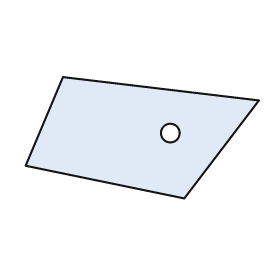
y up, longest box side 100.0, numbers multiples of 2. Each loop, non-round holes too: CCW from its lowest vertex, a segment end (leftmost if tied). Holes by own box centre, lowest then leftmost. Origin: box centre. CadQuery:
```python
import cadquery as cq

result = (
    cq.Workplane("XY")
    .moveTo(18.0, -26.0)
    .lineTo(50.0, 16.0)
    .lineTo(-34.0, 26.0)
    .lineTo(-50.0, -12.0)
    .close()
    .moveTo(12.0, 2.0)
    .circle(4.0)
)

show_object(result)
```